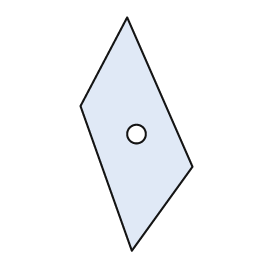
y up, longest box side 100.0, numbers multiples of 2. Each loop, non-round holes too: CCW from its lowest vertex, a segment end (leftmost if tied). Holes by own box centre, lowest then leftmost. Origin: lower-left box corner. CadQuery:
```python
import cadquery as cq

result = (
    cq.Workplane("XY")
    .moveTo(22.0, 0.0)
    .lineTo(48.0, 36.0)
    .lineTo(20.0, 100.0)
    .lineTo(0.0, 62.0)
    .close()
    .moveTo(24.0, 50.0)
    .circle(4.0)
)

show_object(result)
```